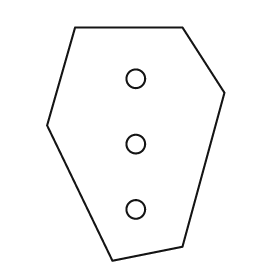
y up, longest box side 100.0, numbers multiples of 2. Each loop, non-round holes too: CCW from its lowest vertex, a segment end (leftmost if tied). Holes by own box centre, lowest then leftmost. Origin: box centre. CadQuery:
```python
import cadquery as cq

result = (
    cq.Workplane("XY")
    .moveTo(-10.0, -50.0)
    .lineTo(20.0, -44.0)
    .lineTo(38.0, 22.0)
    .lineTo(20.0, 50.0)
    .lineTo(-26.0, 50.0)
    .lineTo(-38.0, 8.0)
    .close()
    .moveTo(0.0, -28.0)
    .circle(4.0)
    .moveTo(0.0, 0.0)
    .circle(4.0)
    .moveTo(0.0, 28.0)
    .circle(4.0)
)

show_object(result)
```